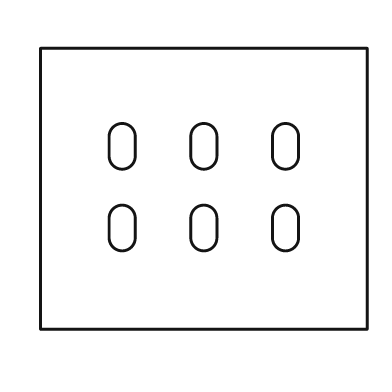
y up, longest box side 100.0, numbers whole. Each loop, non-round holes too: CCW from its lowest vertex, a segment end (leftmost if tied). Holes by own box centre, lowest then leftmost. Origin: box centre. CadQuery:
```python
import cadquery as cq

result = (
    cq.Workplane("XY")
    .moveTo(-50.0, -43.0)
    .lineTo(50.0, -43.0)
    .lineTo(50.0, 43.0)
    .lineTo(-50.0, 43.0)
    .close()
    .moveTo(-29.0, -15.0)
    .threePointArc((-25.0, -19.0), (-21.0, -15.0))
    .lineTo(-21.0, -9.0)
    .threePointArc((-25.0, -5.0), (-29.0, -9.0))
    .close()
    .moveTo(-4.0, -15.0)
    .threePointArc((0.0, -19.0), (4.0, -15.0))
    .lineTo(4.0, -9.0)
    .threePointArc((0.0, -5.0), (-4.0, -9.0))
    .close()
    .moveTo(21.0, -15.0)
    .threePointArc((25.0, -19.0), (29.0, -15.0))
    .lineTo(29.0, -9.0)
    .threePointArc((25.0, -5.0), (21.0, -9.0))
    .close()
    .moveTo(-29.0, 10.0)
    .threePointArc((-25.0, 6.0), (-21.0, 10.0))
    .lineTo(-21.0, 16.0)
    .threePointArc((-25.0, 20.0), (-29.0, 16.0))
    .close()
    .moveTo(-4.0, 10.0)
    .threePointArc((0.0, 6.0), (4.0, 10.0))
    .lineTo(4.0, 16.0)
    .threePointArc((0.0, 20.0), (-4.0, 16.0))
    .close()
    .moveTo(21.0, 10.0)
    .threePointArc((25.0, 6.0), (29.0, 10.0))
    .lineTo(29.0, 16.0)
    .threePointArc((25.0, 20.0), (21.0, 16.0))
    .close()
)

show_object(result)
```